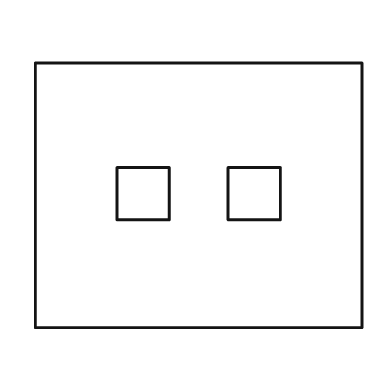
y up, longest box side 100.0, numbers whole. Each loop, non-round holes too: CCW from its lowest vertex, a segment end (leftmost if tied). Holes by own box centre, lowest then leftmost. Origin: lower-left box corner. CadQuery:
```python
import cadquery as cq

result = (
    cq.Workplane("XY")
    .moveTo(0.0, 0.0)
    .lineTo(100.0, 0.0)
    .lineTo(100.0, 81.0)
    .lineTo(0.0, 81.0)
    .close()
    .moveTo(25.0, 33.0)
    .lineTo(41.0, 33.0)
    .lineTo(41.0, 49.0)
    .lineTo(25.0, 49.0)
    .close()
    .moveTo(59.0, 33.0)
    .lineTo(75.0, 33.0)
    .lineTo(75.0, 49.0)
    .lineTo(59.0, 49.0)
    .close()
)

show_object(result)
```